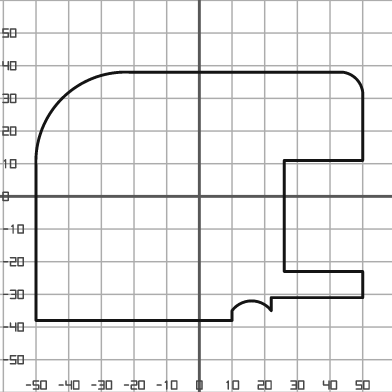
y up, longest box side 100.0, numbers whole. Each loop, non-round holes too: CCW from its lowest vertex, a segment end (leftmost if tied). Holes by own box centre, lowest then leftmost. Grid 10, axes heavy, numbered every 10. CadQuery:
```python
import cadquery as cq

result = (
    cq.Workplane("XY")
    .moveTo(-50.0, -38.0)
    .lineTo(10.0, -38.0)
    .lineTo(10.0, -35.0)
    .threePointArc((16.0, -32.0), (22.0, -35.0))
    .lineTo(22.0, -31.0)
    .lineTo(50.0, -31.0)
    .lineTo(50.0, -23.0)
    .lineTo(26.0, -23.0)
    .lineTo(26.0, 11.0)
    .lineTo(50.0, 11.0)
    .lineTo(50.0, 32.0)
    .threePointArc((48.0, 36.0), (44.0, 38.0))
    .lineTo(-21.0, 38.0)
    .threePointArc((-42.0, 30.0), (-50.0, 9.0))
    .close()
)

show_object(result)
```